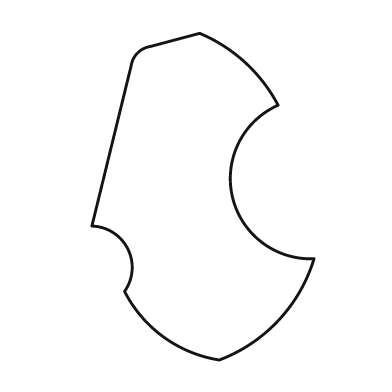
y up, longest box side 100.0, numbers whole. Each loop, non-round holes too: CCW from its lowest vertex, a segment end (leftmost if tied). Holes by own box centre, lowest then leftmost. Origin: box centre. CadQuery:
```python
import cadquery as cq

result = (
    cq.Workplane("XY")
    .moveTo(5.0, -50.0)
    .threePointArc((23.0, -38.0), (34.0, -19.0))
    .threePointArc((9.0, 0.0), (23.0, 28.0))
    .threePointArc((13.0, 41.0), (-1.0, 50.0))
    .lineTo(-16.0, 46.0)
    .threePointArc((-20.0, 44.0), (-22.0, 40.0))
    .lineTo(-34.0, -9.0)
    .threePointArc((-23.0, -16.0), (-24.0, -29.0))
    .threePointArc((-12.0, -43.0), (5.0, -50.0))
    .close()
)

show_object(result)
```